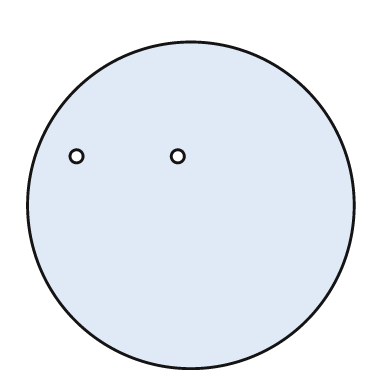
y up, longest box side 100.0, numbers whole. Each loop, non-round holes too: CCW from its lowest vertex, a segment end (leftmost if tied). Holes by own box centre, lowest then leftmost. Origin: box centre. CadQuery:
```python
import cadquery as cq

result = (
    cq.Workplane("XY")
    .moveTo(0.0, 0.0)
    .circle(50.0)
    .moveTo(-35.0, 15.0)
    .circle(2.0)
    .moveTo(-4.0, 15.0)
    .circle(2.0)
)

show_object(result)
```